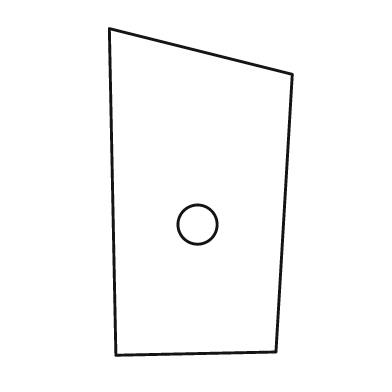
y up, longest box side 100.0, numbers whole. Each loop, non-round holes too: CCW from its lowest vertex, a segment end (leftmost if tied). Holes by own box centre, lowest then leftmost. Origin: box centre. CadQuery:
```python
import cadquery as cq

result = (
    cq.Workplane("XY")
    .moveTo(-26.0, -50.0)
    .lineTo(23.0, -49.0)
    .lineTo(28.0, 36.0)
    .lineTo(-28.0, 50.0)
    .close()
    .moveTo(-1.0, -10.0)
    .circle(6.0)
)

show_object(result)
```